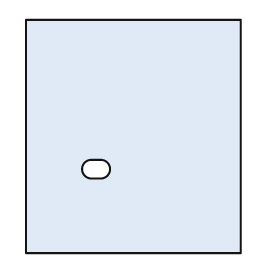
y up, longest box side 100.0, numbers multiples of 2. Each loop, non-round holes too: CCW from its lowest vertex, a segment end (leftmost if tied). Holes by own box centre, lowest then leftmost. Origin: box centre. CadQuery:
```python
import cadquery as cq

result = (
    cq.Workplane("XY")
    .moveTo(-46.0, -50.0)
    .lineTo(46.0, -50.0)
    .lineTo(46.0, 50.0)
    .lineTo(-46.0, 50.0)
    .close()
    .moveTo(-18.0, -18.0)
    .lineTo(-14.0, -18.0)
    .threePointArc((-10.0, -14.0), (-14.0, -10.0))
    .lineTo(-18.0, -10.0)
    .threePointArc((-22.0, -14.0), (-18.0, -18.0))
    .close()
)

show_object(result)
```